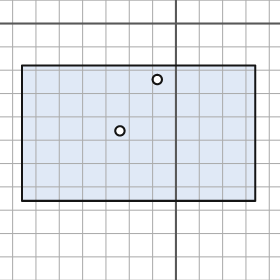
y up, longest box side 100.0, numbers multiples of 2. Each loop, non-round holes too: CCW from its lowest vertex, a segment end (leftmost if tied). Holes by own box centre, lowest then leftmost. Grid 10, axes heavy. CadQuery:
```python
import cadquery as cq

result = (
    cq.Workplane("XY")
    .moveTo(-66.0, -76.0)
    .lineTo(34.0, -76.0)
    .lineTo(34.0, -18.0)
    .lineTo(-66.0, -18.0)
    .close()
    .moveTo(-24.0, -46.0)
    .circle(2.0)
    .moveTo(-8.0, -24.0)
    .circle(2.0)
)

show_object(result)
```